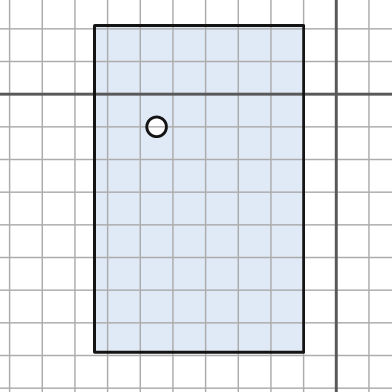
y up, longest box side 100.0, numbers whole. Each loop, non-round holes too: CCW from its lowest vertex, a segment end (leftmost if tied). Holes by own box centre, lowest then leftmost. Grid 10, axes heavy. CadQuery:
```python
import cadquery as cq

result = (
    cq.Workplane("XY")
    .moveTo(-74.0, -79.0)
    .lineTo(-10.0, -79.0)
    .lineTo(-10.0, 21.0)
    .lineTo(-74.0, 21.0)
    .close()
    .moveTo(-55.0, -10.0)
    .circle(3.0)
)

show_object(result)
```